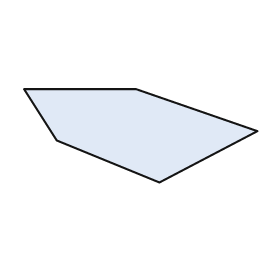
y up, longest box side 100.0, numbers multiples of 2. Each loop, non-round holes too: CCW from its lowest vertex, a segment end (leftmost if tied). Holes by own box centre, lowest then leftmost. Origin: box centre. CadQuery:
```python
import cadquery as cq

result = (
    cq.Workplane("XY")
    .moveTo(8.0, -20.0)
    .lineTo(50.0, 2.0)
    .lineTo(-2.0, 20.0)
    .lineTo(-50.0, 20.0)
    .lineTo(-36.0, -2.0)
    .close()
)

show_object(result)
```